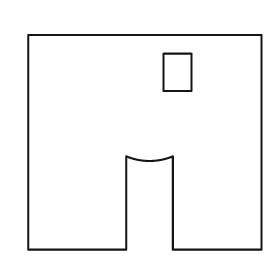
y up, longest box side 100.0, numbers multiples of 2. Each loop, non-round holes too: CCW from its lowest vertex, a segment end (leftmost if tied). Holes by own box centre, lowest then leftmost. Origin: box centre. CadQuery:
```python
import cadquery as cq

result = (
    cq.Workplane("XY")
    .moveTo(-50.0, -46.0)
    .lineTo(-8.0, -46.0)
    .lineTo(-8.0, -6.0)
    .threePointArc((2.0, -8.0), (12.0, -6.0))
    .lineTo(12.0, -46.0)
    .lineTo(50.0, -46.0)
    .lineTo(50.0, 46.0)
    .lineTo(-50.0, 46.0)
    .close()
    .moveTo(8.0, 22.0)
    .lineTo(20.0, 22.0)
    .lineTo(20.0, 38.0)
    .lineTo(8.0, 38.0)
    .close()
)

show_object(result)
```